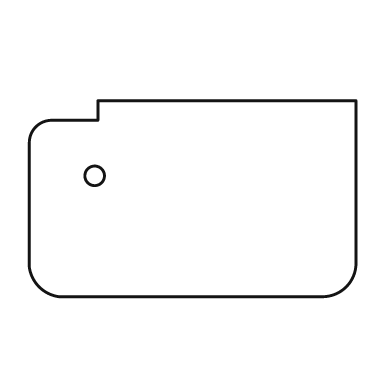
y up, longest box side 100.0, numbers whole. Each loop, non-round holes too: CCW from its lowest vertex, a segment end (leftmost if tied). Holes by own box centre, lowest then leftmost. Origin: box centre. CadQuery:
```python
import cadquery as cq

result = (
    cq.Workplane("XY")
    .moveTo(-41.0, -30.0)
    .lineTo(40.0, -30.0)
    .threePointArc((47.0, -27.0), (50.0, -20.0))
    .lineTo(50.0, 30.0)
    .lineTo(-29.0, 30.0)
    .lineTo(-29.0, 24.0)
    .lineTo(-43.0, 24.0)
    .threePointArc((-48.0, 22.0), (-50.0, 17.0))
    .lineTo(-50.0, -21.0)
    .threePointArc((-47.0, -27.0), (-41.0, -30.0))
    .close()
    .moveTo(-30.0, 7.0)
    .circle(3.0)
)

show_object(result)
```